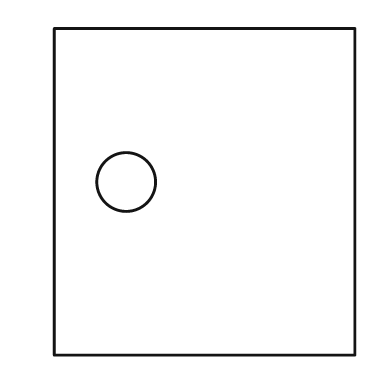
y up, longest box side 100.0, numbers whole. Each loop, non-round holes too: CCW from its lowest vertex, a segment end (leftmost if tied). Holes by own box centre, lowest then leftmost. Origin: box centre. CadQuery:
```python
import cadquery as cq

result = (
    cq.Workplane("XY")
    .moveTo(-46.0, -50.0)
    .lineTo(46.0, -50.0)
    .lineTo(46.0, 50.0)
    .lineTo(-46.0, 50.0)
    .close()
    .moveTo(-24.0, 3.0)
    .circle(9.0)
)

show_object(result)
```